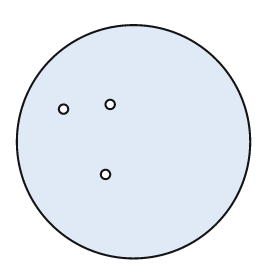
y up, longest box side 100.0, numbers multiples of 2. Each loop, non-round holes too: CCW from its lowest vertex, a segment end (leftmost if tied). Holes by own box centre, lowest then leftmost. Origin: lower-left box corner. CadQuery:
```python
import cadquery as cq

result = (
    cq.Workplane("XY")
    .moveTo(50.0, 50.0)
    .circle(50.0)
    .moveTo(38.0, 36.0)
    .circle(2.0)
    .moveTo(20.0, 64.0)
    .circle(2.0)
    .moveTo(40.0, 66.0)
    .circle(2.0)
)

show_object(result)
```